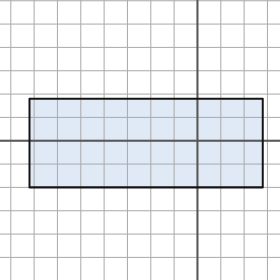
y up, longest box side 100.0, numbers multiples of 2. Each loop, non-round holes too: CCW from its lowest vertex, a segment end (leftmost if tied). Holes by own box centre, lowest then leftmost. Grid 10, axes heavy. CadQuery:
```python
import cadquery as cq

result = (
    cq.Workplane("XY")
    .moveTo(-72.0, -20.0)
    .lineTo(28.0, -20.0)
    .lineTo(28.0, 18.0)
    .lineTo(-72.0, 18.0)
    .close()
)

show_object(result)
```